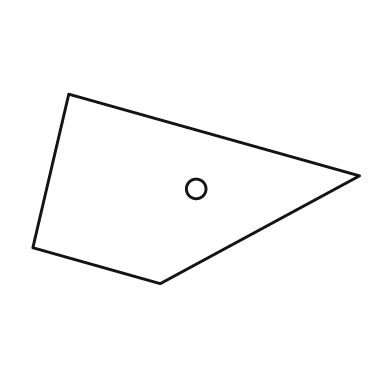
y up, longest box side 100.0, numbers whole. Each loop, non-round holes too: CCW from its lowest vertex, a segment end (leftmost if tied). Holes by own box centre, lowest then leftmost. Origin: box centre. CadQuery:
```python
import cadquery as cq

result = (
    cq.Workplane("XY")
    .moveTo(-11.0, -29.0)
    .lineTo(50.0, 4.0)
    .lineTo(-39.0, 29.0)
    .lineTo(-50.0, -18.0)
    .close()
    .moveTo(0.0, 0.0)
    .circle(3.0)
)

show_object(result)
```